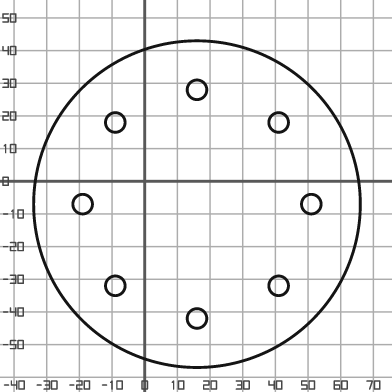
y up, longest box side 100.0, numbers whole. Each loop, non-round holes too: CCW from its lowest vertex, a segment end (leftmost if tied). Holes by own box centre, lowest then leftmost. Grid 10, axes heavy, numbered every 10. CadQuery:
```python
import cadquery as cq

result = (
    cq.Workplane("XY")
    .moveTo(16.0, -7.0)
    .circle(50.0)
    .moveTo(16.0, -42.0)
    .circle(3.0)
    .moveTo(-9.0, -32.0)
    .circle(3.0)
    .moveTo(41.0, -32.0)
    .circle(3.0)
    .moveTo(-19.0, -7.0)
    .circle(3.0)
    .moveTo(51.0, -7.0)
    .circle(3.0)
    .moveTo(-9.0, 18.0)
    .circle(3.0)
    .moveTo(41.0, 18.0)
    .circle(3.0)
    .moveTo(16.0, 28.0)
    .circle(3.0)
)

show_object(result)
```